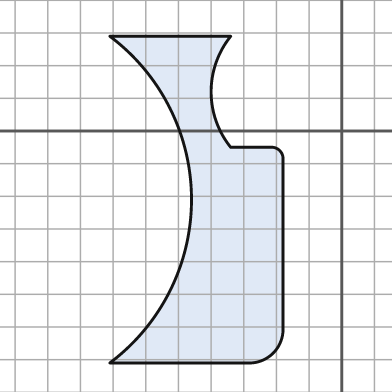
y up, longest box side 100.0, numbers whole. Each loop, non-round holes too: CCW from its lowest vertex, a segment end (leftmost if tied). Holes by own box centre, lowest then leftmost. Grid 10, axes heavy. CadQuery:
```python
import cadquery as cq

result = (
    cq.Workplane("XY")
    .moveTo(-71.0, -71.0)
    .lineTo(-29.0, -71.0)
    .threePointArc((-21.0, -68.0), (-18.0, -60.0))
    .lineTo(-18.0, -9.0)
    .threePointArc((-19.0, -6.0), (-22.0, -5.0))
    .lineTo(-34.0, -5.0)
    .threePointArc((-40.0, 12.0), (-34.0, 29.0))
    .lineTo(-71.0, 29.0)
    .threePointArc((-46.0, -21.0), (-71.0, -71.0))
    .close()
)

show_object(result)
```